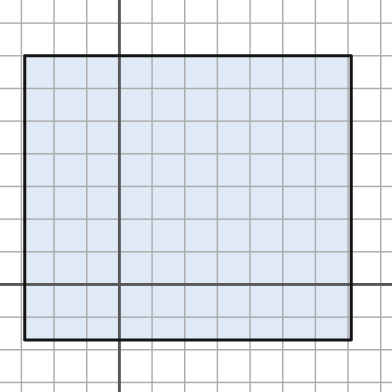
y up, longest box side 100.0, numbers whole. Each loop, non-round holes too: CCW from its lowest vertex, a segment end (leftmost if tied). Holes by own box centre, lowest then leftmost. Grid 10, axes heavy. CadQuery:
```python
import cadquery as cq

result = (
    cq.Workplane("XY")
    .moveTo(-29.0, -17.0)
    .lineTo(71.0, -17.0)
    .lineTo(71.0, 70.0)
    .lineTo(-29.0, 70.0)
    .close()
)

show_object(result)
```